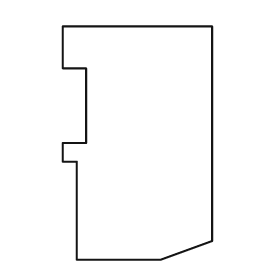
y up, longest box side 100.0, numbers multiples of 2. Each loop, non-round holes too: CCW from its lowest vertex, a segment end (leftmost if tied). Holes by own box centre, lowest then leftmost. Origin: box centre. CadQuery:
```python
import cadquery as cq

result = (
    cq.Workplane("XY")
    .moveTo(-26.0, -50.0)
    .lineTo(10.0, -50.0)
    .lineTo(32.0, -42.0)
    .lineTo(32.0, 50.0)
    .lineTo(-32.0, 50.0)
    .lineTo(-32.0, 32.0)
    .lineTo(-22.0, 32.0)
    .lineTo(-22.0, 0.0)
    .lineTo(-32.0, 0.0)
    .lineTo(-32.0, -8.0)
    .lineTo(-26.0, -8.0)
    .close()
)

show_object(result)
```